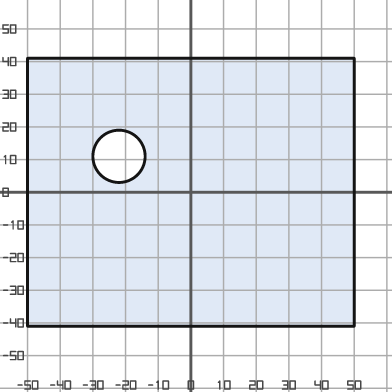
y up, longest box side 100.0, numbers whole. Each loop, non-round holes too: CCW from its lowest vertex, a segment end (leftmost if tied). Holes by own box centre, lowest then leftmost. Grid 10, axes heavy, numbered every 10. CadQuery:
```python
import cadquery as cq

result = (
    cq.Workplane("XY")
    .moveTo(-50.0, -41.0)
    .lineTo(50.0, -41.0)
    .lineTo(50.0, 41.0)
    .lineTo(-50.0, 41.0)
    .close()
    .moveTo(-22.0, 11.0)
    .circle(8.0)
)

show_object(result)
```